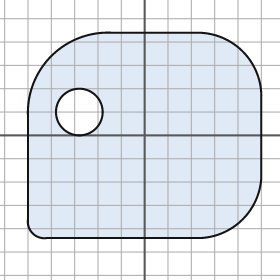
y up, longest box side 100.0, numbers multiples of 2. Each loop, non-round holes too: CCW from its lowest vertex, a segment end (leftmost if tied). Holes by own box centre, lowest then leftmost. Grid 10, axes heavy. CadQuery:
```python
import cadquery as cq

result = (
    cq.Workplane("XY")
    .moveTo(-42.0, -44.0)
    .lineTo(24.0, -44.0)
    .threePointArc((42.0, -36.0), (50.0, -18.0))
    .lineTo(50.0, 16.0)
    .threePointArc((42.0, 36.0), (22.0, 44.0))
    .lineTo(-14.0, 44.0)
    .threePointArc((-40.0, 34.0), (-50.0, 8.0))
    .lineTo(-50.0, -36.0)
    .threePointArc((-48.0, -42.0), (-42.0, -44.0))
    .close()
    .moveTo(-28.0, 10.0)
    .circle(10.0)
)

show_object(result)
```